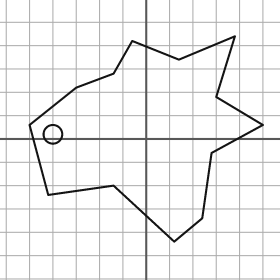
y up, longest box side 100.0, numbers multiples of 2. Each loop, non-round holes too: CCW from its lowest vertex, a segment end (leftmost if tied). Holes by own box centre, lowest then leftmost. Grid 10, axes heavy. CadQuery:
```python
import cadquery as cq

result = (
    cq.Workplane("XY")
    .moveTo(12.0, -44.0)
    .lineTo(24.0, -34.0)
    .lineTo(28.0, -6.0)
    .lineTo(50.0, 6.0)
    .lineTo(30.0, 18.0)
    .lineTo(38.0, 44.0)
    .lineTo(14.0, 34.0)
    .lineTo(-6.0, 42.0)
    .lineTo(-14.0, 28.0)
    .lineTo(-30.0, 22.0)
    .lineTo(-50.0, 6.0)
    .lineTo(-42.0, -24.0)
    .lineTo(-14.0, -20.0)
    .close()
    .moveTo(-40.0, 2.0)
    .circle(4.0)
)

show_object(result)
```